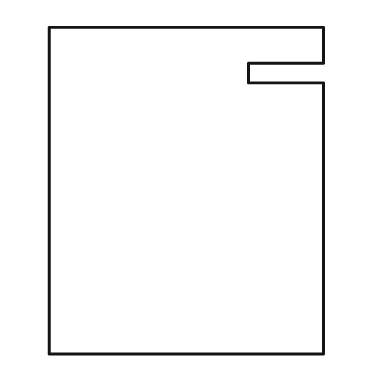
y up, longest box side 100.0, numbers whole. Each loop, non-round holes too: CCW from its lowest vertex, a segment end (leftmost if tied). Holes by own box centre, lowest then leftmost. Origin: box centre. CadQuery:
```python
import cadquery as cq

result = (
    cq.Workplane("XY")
    .moveTo(-42.0, -50.0)
    .lineTo(42.0, -50.0)
    .lineTo(42.0, 33.0)
    .lineTo(19.0, 33.0)
    .lineTo(19.0, 39.0)
    .lineTo(42.0, 39.0)
    .lineTo(42.0, 50.0)
    .lineTo(-42.0, 50.0)
    .close()
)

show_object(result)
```